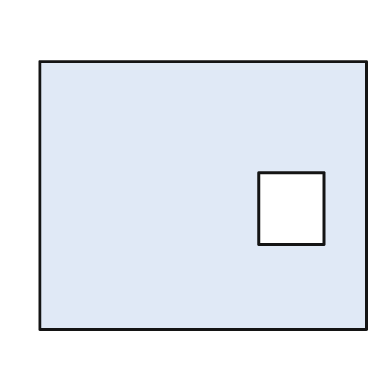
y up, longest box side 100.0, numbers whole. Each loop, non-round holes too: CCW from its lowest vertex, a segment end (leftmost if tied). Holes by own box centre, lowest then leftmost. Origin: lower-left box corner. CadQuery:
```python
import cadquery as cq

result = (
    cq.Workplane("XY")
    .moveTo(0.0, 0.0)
    .lineTo(100.0, 0.0)
    .lineTo(100.0, 82.0)
    .lineTo(0.0, 82.0)
    .close()
    .moveTo(67.0, 26.0)
    .lineTo(87.0, 26.0)
    .lineTo(87.0, 48.0)
    .lineTo(67.0, 48.0)
    .close()
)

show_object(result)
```